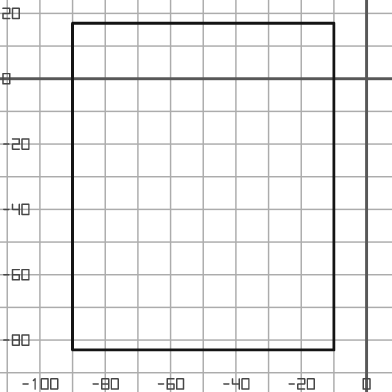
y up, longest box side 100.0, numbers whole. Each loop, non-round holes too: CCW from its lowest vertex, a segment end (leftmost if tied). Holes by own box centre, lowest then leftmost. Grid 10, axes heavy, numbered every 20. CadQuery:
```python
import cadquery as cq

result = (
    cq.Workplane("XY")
    .moveTo(-90.0, -83.0)
    .lineTo(-10.0, -83.0)
    .lineTo(-10.0, 17.0)
    .lineTo(-90.0, 17.0)
    .close()
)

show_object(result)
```